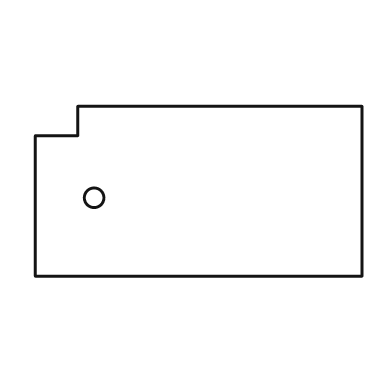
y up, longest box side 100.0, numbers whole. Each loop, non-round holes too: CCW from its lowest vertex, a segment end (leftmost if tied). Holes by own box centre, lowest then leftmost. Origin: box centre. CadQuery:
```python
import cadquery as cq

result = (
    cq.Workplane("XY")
    .moveTo(-50.0, -26.0)
    .lineTo(50.0, -26.0)
    .lineTo(50.0, 26.0)
    .lineTo(-37.0, 26.0)
    .lineTo(-37.0, 17.0)
    .lineTo(-50.0, 17.0)
    .close()
    .moveTo(-32.0, -2.0)
    .circle(3.0)
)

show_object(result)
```